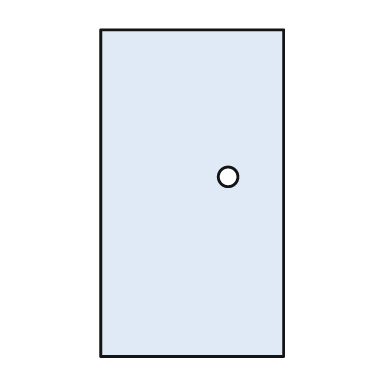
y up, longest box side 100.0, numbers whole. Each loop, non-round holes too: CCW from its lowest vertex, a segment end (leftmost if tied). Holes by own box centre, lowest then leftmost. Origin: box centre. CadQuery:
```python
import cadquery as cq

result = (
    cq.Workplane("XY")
    .moveTo(-28.0, -50.0)
    .lineTo(28.0, -50.0)
    .lineTo(28.0, 50.0)
    .lineTo(-28.0, 50.0)
    .close()
    .moveTo(11.0, 5.0)
    .circle(3.0)
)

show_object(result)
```